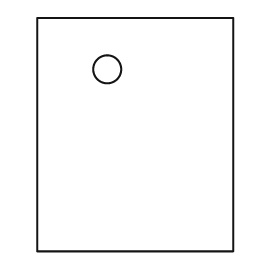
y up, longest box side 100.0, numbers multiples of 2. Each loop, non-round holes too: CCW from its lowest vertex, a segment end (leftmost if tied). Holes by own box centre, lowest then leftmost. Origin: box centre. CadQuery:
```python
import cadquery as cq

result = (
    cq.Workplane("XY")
    .moveTo(-42.0, -50.0)
    .lineTo(42.0, -50.0)
    .lineTo(42.0, 50.0)
    .lineTo(-42.0, 50.0)
    .close()
    .moveTo(-12.0, 28.0)
    .circle(6.0)
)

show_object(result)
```